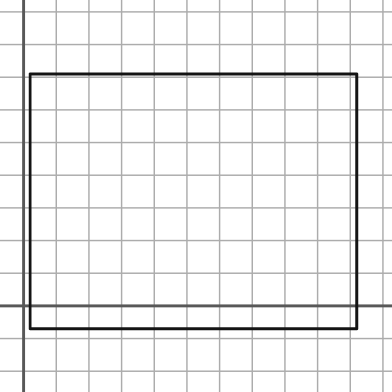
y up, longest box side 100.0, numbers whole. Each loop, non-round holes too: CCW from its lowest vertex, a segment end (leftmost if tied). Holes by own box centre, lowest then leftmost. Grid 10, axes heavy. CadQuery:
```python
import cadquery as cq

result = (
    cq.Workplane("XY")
    .moveTo(2.0, -7.0)
    .lineTo(102.0, -7.0)
    .lineTo(102.0, 71.0)
    .lineTo(2.0, 71.0)
    .close()
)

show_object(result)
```